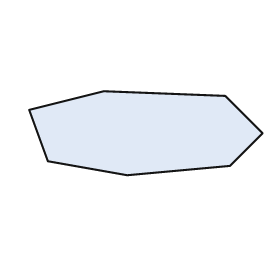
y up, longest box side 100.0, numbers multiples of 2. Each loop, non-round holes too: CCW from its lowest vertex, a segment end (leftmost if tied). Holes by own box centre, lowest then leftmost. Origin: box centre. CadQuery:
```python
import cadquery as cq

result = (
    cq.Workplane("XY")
    .moveTo(-8.0, -18.0)
    .lineTo(36.0, -14.0)
    .lineTo(50.0, 0.0)
    .lineTo(34.0, 16.0)
    .lineTo(-18.0, 18.0)
    .lineTo(-50.0, 10.0)
    .lineTo(-42.0, -12.0)
    .close()
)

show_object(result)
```